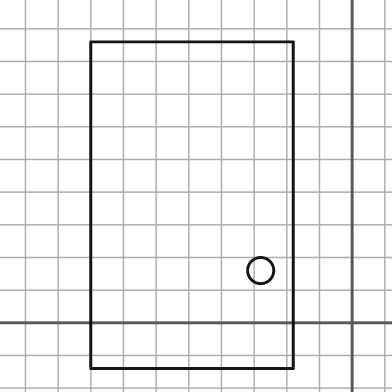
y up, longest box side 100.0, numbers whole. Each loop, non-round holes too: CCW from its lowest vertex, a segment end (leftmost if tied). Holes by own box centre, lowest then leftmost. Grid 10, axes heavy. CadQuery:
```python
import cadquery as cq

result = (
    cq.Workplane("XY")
    .moveTo(-80.0, -14.0)
    .lineTo(-18.0, -14.0)
    .lineTo(-18.0, 86.0)
    .lineTo(-80.0, 86.0)
    .close()
    .moveTo(-28.0, 16.0)
    .circle(4.0)
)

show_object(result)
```